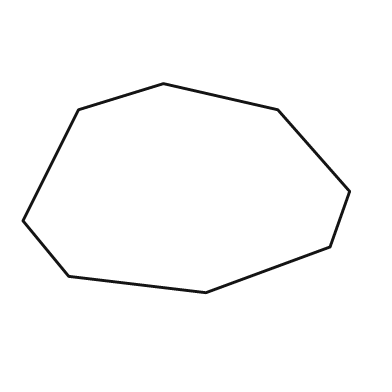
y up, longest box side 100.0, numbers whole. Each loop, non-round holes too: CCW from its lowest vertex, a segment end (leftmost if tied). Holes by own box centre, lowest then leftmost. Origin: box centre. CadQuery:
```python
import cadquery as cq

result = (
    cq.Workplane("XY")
    .moveTo(6.0, -32.0)
    .lineTo(44.0, -18.0)
    .lineTo(50.0, -1.0)
    .lineTo(28.0, 24.0)
    .lineTo(-7.0, 32.0)
    .lineTo(-33.0, 24.0)
    .lineTo(-50.0, -10.0)
    .lineTo(-36.0, -27.0)
    .close()
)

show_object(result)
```